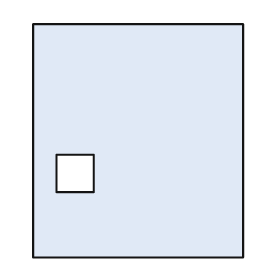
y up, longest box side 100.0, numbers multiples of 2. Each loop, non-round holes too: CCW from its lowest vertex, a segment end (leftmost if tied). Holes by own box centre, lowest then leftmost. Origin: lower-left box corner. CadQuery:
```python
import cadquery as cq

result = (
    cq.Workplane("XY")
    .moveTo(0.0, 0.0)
    .lineTo(90.0, 0.0)
    .lineTo(90.0, 100.0)
    .lineTo(0.0, 100.0)
    .close()
    .moveTo(10.0, 28.0)
    .lineTo(26.0, 28.0)
    .lineTo(26.0, 44.0)
    .lineTo(10.0, 44.0)
    .close()
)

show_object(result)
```